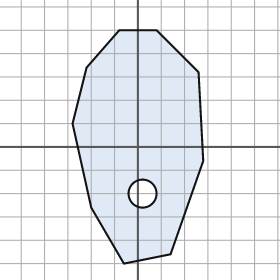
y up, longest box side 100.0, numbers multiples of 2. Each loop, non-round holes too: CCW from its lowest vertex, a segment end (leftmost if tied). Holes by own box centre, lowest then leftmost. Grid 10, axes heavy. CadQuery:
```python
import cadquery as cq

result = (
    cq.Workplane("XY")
    .moveTo(-6.0, -50.0)
    .lineTo(14.0, -46.0)
    .lineTo(28.0, -6.0)
    .lineTo(26.0, 32.0)
    .lineTo(8.0, 50.0)
    .lineTo(-8.0, 50.0)
    .lineTo(-22.0, 34.0)
    .lineTo(-28.0, 10.0)
    .lineTo(-20.0, -26.0)
    .close()
    .moveTo(2.0, -20.0)
    .circle(6.0)
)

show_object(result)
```